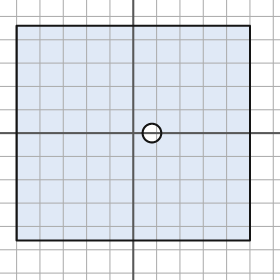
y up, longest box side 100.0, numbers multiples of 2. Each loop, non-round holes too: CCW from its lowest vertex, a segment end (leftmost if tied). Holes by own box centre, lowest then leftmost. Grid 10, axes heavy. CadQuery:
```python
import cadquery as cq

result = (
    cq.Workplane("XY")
    .moveTo(-50.0, -46.0)
    .lineTo(50.0, -46.0)
    .lineTo(50.0, 46.0)
    .lineTo(-50.0, 46.0)
    .close()
    .moveTo(8.0, 0.0)
    .circle(4.0)
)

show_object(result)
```